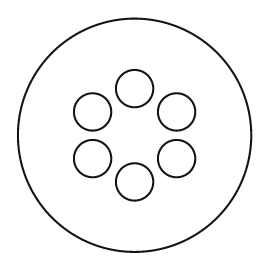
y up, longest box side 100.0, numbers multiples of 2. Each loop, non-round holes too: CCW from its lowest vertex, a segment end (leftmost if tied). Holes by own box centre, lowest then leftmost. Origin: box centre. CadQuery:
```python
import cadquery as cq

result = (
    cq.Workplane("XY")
    .moveTo(0.0, 0.0)
    .circle(50.0)
    .moveTo(0.0, -20.0)
    .circle(8.0)
    .moveTo(-18.0, -10.0)
    .circle(8.0)
    .moveTo(18.0, -10.0)
    .circle(8.0)
    .moveTo(-18.0, 10.0)
    .circle(8.0)
    .moveTo(18.0, 10.0)
    .circle(8.0)
    .moveTo(0.0, 20.0)
    .circle(8.0)
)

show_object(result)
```